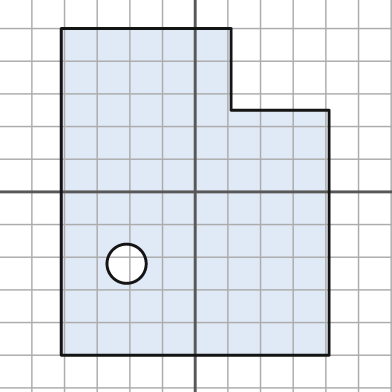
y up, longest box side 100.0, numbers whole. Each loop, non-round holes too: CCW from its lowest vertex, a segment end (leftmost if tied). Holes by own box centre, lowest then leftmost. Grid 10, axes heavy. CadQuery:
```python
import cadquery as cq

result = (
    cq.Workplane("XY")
    .moveTo(-41.0, -50.0)
    .lineTo(41.0, -50.0)
    .lineTo(41.0, 25.0)
    .lineTo(11.0, 25.0)
    .lineTo(11.0, 50.0)
    .lineTo(-41.0, 50.0)
    .close()
    .moveTo(-21.0, -22.0)
    .circle(6.0)
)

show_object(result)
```